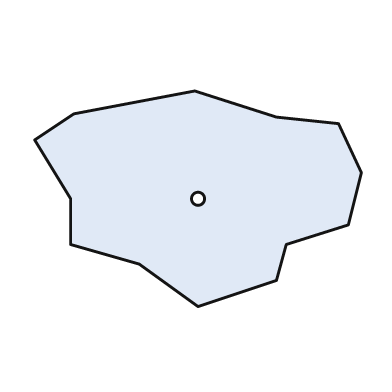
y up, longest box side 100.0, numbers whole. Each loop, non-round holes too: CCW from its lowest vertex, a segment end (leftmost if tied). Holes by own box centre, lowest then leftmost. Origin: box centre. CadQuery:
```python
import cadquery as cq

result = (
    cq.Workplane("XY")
    .moveTo(0.0, -33.0)
    .lineTo(24.0, -25.0)
    .lineTo(27.0, -14.0)
    .lineTo(46.0, -8.0)
    .lineTo(50.0, 8.0)
    .lineTo(43.0, 23.0)
    .lineTo(24.0, 25.0)
    .lineTo(-1.0, 33.0)
    .lineTo(-38.0, 26.0)
    .lineTo(-50.0, 18.0)
    .lineTo(-39.0, 0.0)
    .lineTo(-39.0, -14.0)
    .lineTo(-18.0, -20.0)
    .close()
    .moveTo(0.0, 0.0)
    .circle(2.0)
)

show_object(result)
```